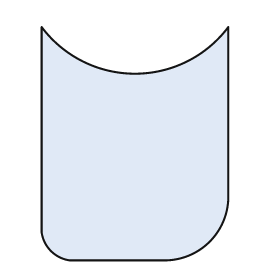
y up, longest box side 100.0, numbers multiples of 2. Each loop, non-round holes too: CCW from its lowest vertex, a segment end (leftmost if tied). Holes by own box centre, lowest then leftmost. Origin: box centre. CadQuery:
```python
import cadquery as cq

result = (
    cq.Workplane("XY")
    .moveTo(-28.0, -50.0)
    .lineTo(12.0, -50.0)
    .threePointArc((32.0, -42.0), (40.0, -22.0))
    .lineTo(40.0, 50.0)
    .threePointArc((0.0, 30.0), (-40.0, 50.0))
    .lineTo(-40.0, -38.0)
    .threePointArc((-36.0, -46.0), (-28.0, -50.0))
    .close()
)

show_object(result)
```